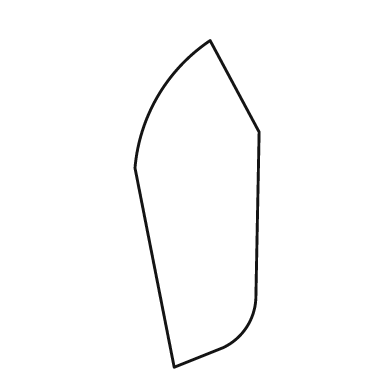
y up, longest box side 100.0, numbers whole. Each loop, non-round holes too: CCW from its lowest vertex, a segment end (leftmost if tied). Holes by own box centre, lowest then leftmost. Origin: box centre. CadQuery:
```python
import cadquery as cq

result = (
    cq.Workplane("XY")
    .moveTo(-7.0, -50.0)
    .lineTo(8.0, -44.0)
    .threePointArc((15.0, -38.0), (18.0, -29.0))
    .lineTo(19.0, 22.0)
    .lineTo(4.0, 50.0)
    .threePointArc((-12.0, 33.0), (-19.0, 11.0))
    .close()
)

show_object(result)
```